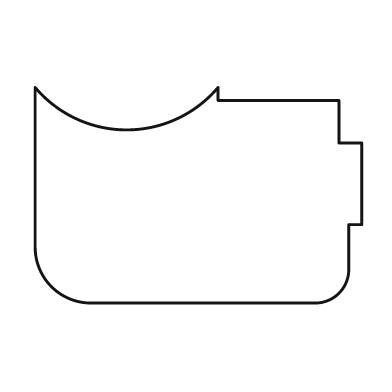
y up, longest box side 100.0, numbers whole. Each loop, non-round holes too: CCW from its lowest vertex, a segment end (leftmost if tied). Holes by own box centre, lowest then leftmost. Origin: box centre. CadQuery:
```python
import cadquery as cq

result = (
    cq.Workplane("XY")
    .moveTo(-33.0, -33.0)
    .lineTo(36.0, -33.0)
    .threePointArc((43.0, -30.0), (46.0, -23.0))
    .lineTo(46.0, -9.0)
    .lineTo(50.0, -9.0)
    .lineTo(50.0, 16.0)
    .lineTo(43.0, 16.0)
    .lineTo(43.0, 29.0)
    .lineTo(6.0, 29.0)
    .lineTo(6.0, 33.0)
    .threePointArc((-22.0, 20.0), (-50.0, 33.0))
    .lineTo(-50.0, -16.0)
    .threePointArc((-45.0, -28.0), (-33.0, -33.0))
    .close()
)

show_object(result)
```